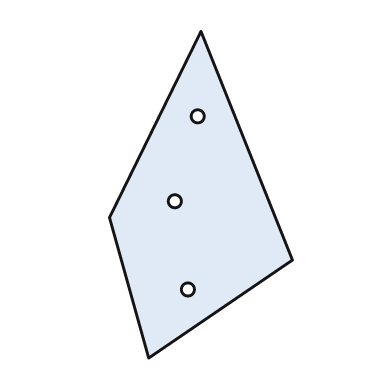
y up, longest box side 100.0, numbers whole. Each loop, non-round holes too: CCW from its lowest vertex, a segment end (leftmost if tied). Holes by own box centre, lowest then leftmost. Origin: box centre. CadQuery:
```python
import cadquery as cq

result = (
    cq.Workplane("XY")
    .moveTo(-16.0, -50.0)
    .lineTo(28.0, -20.0)
    .lineTo(0.0, 50.0)
    .lineTo(-28.0, -7.0)
    .close()
    .moveTo(-4.0, -29.0)
    .circle(2.0)
    .moveTo(-8.0, -2.0)
    .circle(2.0)
    .moveTo(-1.0, 24.0)
    .circle(2.0)
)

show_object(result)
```